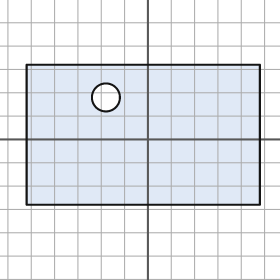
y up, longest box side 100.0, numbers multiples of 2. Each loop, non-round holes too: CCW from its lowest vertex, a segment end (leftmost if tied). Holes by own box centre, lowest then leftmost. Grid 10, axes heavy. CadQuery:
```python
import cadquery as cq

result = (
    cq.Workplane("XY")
    .moveTo(-52.0, -28.0)
    .lineTo(48.0, -28.0)
    .lineTo(48.0, 32.0)
    .lineTo(-52.0, 32.0)
    .close()
    .moveTo(-18.0, 18.0)
    .circle(6.0)
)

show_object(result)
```